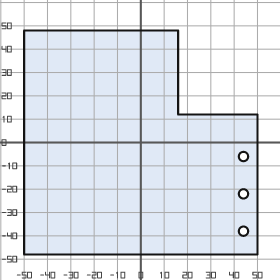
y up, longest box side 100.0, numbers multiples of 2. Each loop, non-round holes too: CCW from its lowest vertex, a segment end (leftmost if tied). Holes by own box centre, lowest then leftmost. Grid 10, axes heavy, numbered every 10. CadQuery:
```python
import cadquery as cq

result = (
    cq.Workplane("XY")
    .moveTo(-50.0, -48.0)
    .lineTo(50.0, -48.0)
    .lineTo(50.0, 12.0)
    .lineTo(16.0, 12.0)
    .lineTo(16.0, 48.0)
    .lineTo(-50.0, 48.0)
    .close()
    .moveTo(44.0, -38.0)
    .circle(2.0)
    .moveTo(44.0, -22.0)
    .circle(2.0)
    .moveTo(44.0, -6.0)
    .circle(2.0)
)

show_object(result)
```